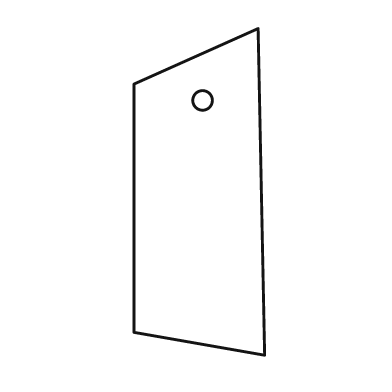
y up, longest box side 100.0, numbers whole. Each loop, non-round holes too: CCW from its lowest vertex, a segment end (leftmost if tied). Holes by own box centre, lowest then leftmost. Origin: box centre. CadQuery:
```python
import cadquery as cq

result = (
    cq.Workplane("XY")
    .moveTo(20.0, -50.0)
    .lineTo(18.0, 50.0)
    .lineTo(-20.0, 33.0)
    .lineTo(-20.0, -43.0)
    .close()
    .moveTo(1.0, 28.0)
    .circle(3.0)
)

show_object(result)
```